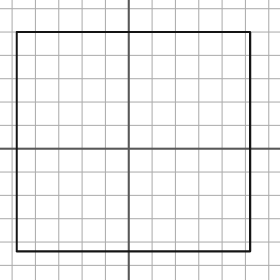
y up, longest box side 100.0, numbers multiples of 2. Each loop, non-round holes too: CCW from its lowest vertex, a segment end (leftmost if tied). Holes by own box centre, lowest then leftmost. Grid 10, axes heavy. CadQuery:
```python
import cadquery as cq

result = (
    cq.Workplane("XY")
    .moveTo(-48.0, -44.0)
    .lineTo(52.0, -44.0)
    .lineTo(52.0, 50.0)
    .lineTo(-48.0, 50.0)
    .close()
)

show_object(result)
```